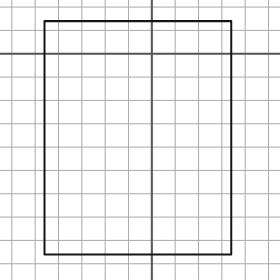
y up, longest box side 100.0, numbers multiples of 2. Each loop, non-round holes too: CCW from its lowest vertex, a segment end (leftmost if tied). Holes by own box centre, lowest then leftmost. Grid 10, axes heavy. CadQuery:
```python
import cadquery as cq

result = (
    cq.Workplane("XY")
    .moveTo(-46.0, -86.0)
    .lineTo(34.0, -86.0)
    .lineTo(34.0, 14.0)
    .lineTo(-46.0, 14.0)
    .close()
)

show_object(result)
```